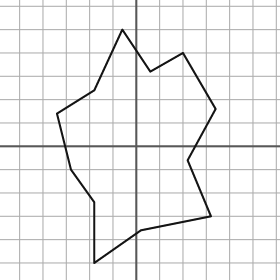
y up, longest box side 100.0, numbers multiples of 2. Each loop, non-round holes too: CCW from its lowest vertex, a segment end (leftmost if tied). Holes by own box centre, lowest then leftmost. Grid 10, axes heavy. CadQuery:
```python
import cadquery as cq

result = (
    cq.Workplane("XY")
    .moveTo(-18.0, -50.0)
    .lineTo(2.0, -36.0)
    .lineTo(32.0, -30.0)
    .lineTo(22.0, -6.0)
    .lineTo(34.0, 16.0)
    .lineTo(20.0, 40.0)
    .lineTo(6.0, 32.0)
    .lineTo(-6.0, 50.0)
    .lineTo(-18.0, 24.0)
    .lineTo(-34.0, 14.0)
    .lineTo(-28.0, -10.0)
    .lineTo(-18.0, -24.0)
    .close()
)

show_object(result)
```